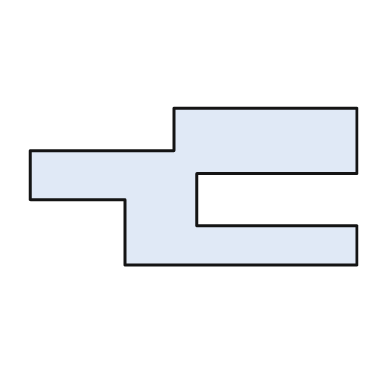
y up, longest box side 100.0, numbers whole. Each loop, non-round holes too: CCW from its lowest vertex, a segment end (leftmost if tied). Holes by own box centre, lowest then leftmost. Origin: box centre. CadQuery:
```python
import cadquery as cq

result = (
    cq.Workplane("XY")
    .moveTo(-21.0, -24.0)
    .lineTo(50.0, -24.0)
    .lineTo(50.0, -12.0)
    .lineTo(1.0, -12.0)
    .lineTo(1.0, 4.0)
    .lineTo(50.0, 4.0)
    .lineTo(50.0, 24.0)
    .lineTo(-6.0, 24.0)
    .lineTo(-6.0, 11.0)
    .lineTo(-50.0, 11.0)
    .lineTo(-50.0, -4.0)
    .lineTo(-21.0, -4.0)
    .close()
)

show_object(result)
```